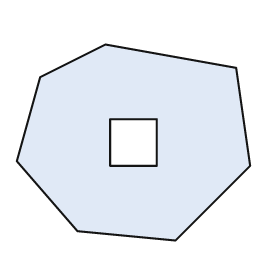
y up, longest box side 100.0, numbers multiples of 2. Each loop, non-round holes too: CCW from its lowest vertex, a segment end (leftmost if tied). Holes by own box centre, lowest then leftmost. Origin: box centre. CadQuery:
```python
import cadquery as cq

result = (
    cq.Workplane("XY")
    .moveTo(18.0, -42.0)
    .lineTo(50.0, -10.0)
    .lineTo(44.0, 32.0)
    .lineTo(-12.0, 42.0)
    .lineTo(-40.0, 28.0)
    .lineTo(-50.0, -8.0)
    .lineTo(-24.0, -38.0)
    .close()
    .moveTo(-10.0, -10.0)
    .lineTo(10.0, -10.0)
    .lineTo(10.0, 10.0)
    .lineTo(-10.0, 10.0)
    .close()
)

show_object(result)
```